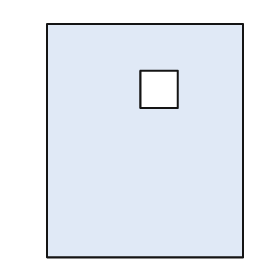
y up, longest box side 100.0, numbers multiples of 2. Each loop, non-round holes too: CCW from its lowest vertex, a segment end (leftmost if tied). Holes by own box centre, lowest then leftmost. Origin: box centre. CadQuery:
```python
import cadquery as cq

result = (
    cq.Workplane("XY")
    .moveTo(-42.0, -50.0)
    .lineTo(42.0, -50.0)
    .lineTo(42.0, 50.0)
    .lineTo(-42.0, 50.0)
    .close()
    .moveTo(-2.0, 14.0)
    .lineTo(14.0, 14.0)
    .lineTo(14.0, 30.0)
    .lineTo(-2.0, 30.0)
    .close()
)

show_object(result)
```